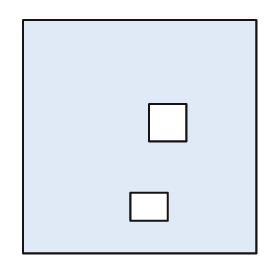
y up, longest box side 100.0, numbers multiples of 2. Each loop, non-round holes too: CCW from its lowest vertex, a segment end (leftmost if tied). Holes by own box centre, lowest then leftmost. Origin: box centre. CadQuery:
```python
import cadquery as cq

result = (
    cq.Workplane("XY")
    .moveTo(-50.0, -50.0)
    .lineTo(50.0, -50.0)
    .lineTo(50.0, 50.0)
    .lineTo(-50.0, 50.0)
    .close()
    .moveTo(-4.0, -36.0)
    .lineTo(12.0, -36.0)
    .lineTo(12.0, -24.0)
    .lineTo(-4.0, -24.0)
    .close()
    .moveTo(4.0, -2.0)
    .lineTo(20.0, -2.0)
    .lineTo(20.0, 14.0)
    .lineTo(4.0, 14.0)
    .close()
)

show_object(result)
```